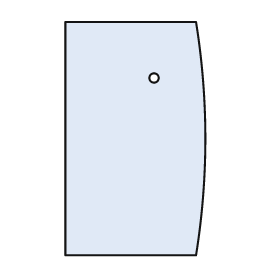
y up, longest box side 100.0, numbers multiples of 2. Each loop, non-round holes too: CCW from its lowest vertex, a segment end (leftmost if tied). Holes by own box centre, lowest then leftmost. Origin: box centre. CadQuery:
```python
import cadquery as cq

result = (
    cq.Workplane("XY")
    .moveTo(-30.0, -50.0)
    .lineTo(26.0, -50.0)
    .threePointArc((30.0, 0.0), (26.0, 50.0))
    .lineTo(-30.0, 50.0)
    .close()
    .moveTo(8.0, 26.0)
    .circle(2.0)
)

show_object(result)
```